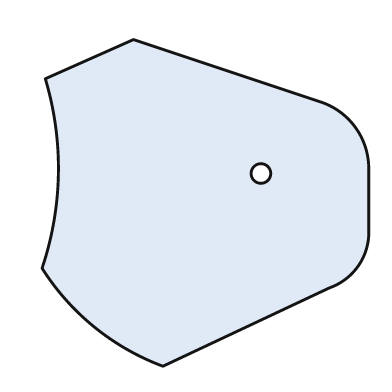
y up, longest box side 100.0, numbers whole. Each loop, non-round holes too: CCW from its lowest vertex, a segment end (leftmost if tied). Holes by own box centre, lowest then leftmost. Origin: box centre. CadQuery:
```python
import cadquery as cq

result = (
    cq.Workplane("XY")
    .moveTo(-13.0, -50.0)
    .lineTo(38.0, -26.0)
    .threePointArc((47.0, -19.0), (50.0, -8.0))
    .lineTo(50.0, 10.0)
    .threePointArc((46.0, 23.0), (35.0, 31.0))
    .lineTo(-22.0, 50.0)
    .lineTo(-49.0, 38.0)
    .threePointArc((-45.0, 9.0), (-50.0, -20.0))
    .threePointArc((-34.0, -38.0), (-13.0, -50.0))
    .close()
    .moveTo(17.0, 9.0)
    .circle(3.0)
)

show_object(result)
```